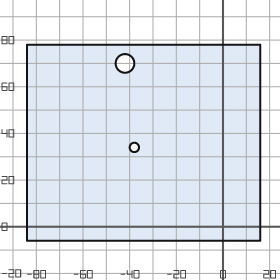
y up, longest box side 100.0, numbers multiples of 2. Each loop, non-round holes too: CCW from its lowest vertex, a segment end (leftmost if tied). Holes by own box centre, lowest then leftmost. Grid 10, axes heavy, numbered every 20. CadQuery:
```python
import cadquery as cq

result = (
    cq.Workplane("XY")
    .moveTo(-84.0, -6.0)
    .lineTo(16.0, -6.0)
    .lineTo(16.0, 78.0)
    .lineTo(-84.0, 78.0)
    .close()
    .moveTo(-38.0, 34.0)
    .circle(2.0)
    .moveTo(-42.0, 70.0)
    .circle(4.0)
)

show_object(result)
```